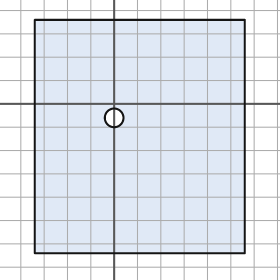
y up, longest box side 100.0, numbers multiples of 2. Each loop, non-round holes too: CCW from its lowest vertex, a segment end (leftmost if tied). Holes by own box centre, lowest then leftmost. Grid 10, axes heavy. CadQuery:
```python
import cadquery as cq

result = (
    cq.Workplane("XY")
    .moveTo(-34.0, -64.0)
    .lineTo(56.0, -64.0)
    .lineTo(56.0, 36.0)
    .lineTo(-34.0, 36.0)
    .close()
    .moveTo(0.0, -6.0)
    .circle(4.0)
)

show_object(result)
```